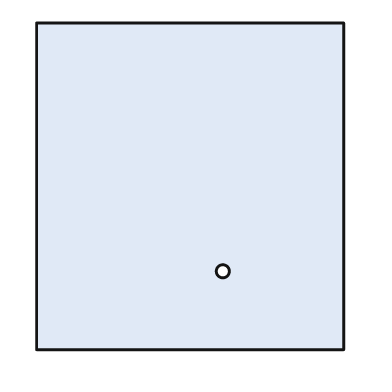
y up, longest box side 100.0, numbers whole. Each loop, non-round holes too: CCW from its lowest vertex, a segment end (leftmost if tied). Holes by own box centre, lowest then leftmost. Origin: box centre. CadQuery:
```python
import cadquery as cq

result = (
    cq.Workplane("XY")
    .moveTo(-47.0, -50.0)
    .lineTo(47.0, -50.0)
    .lineTo(47.0, 50.0)
    .lineTo(-47.0, 50.0)
    .close()
    .moveTo(10.0, -26.0)
    .circle(2.0)
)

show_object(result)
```